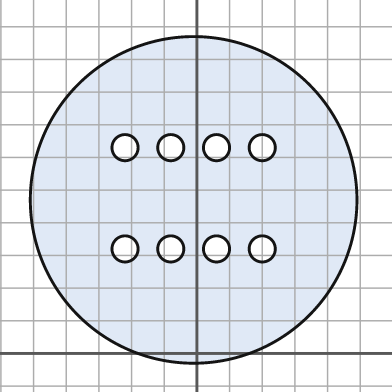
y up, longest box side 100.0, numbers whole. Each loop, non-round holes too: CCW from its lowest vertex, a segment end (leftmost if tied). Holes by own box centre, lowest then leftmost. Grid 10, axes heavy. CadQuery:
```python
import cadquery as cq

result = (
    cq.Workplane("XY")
    .moveTo(-1.0, 47.0)
    .circle(50.0)
    .moveTo(-22.0, 32.0)
    .circle(4.0)
    .moveTo(-8.0, 32.0)
    .circle(4.0)
    .moveTo(6.0, 32.0)
    .circle(4.0)
    .moveTo(20.0, 32.0)
    .circle(4.0)
    .moveTo(-22.0, 63.0)
    .circle(4.0)
    .moveTo(-8.0, 63.0)
    .circle(4.0)
    .moveTo(6.0, 63.0)
    .circle(4.0)
    .moveTo(20.0, 63.0)
    .circle(4.0)
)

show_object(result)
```